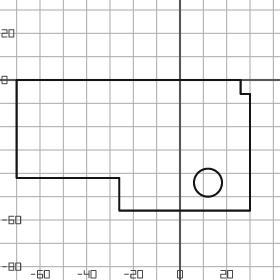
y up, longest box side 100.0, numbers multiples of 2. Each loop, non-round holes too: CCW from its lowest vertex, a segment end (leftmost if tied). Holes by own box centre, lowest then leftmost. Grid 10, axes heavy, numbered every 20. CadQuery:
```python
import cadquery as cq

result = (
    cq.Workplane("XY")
    .moveTo(-26.0, -56.0)
    .lineTo(30.0, -56.0)
    .lineTo(30.0, -6.0)
    .lineTo(26.0, -6.0)
    .lineTo(26.0, 0.0)
    .lineTo(-70.0, 0.0)
    .lineTo(-70.0, -42.0)
    .lineTo(-26.0, -42.0)
    .close()
    .moveTo(12.0, -44.0)
    .circle(6.0)
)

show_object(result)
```